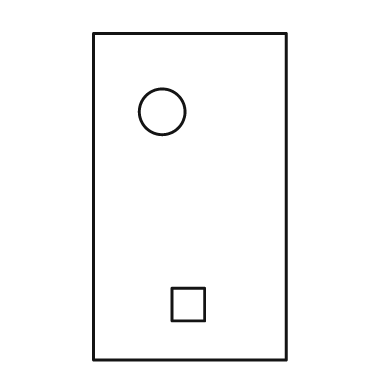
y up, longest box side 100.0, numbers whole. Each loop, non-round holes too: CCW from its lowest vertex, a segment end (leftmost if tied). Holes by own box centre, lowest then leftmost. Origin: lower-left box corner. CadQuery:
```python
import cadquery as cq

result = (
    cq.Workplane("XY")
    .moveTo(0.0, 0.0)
    .lineTo(59.0, 0.0)
    .lineTo(59.0, 100.0)
    .lineTo(0.0, 100.0)
    .close()
    .moveTo(24.0, 12.0)
    .lineTo(34.0, 12.0)
    .lineTo(34.0, 22.0)
    .lineTo(24.0, 22.0)
    .close()
    .moveTo(21.0, 76.0)
    .circle(7.0)
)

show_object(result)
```